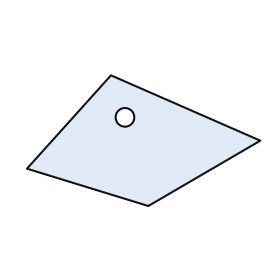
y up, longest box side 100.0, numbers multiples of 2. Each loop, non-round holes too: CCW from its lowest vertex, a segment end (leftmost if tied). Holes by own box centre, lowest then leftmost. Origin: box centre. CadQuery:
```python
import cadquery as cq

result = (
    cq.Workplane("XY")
    .moveTo(2.0, -28.0)
    .lineTo(50.0, 0.0)
    .lineTo(-14.0, 28.0)
    .lineTo(-50.0, -12.0)
    .close()
    .moveTo(-8.0, 10.0)
    .circle(4.0)
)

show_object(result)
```